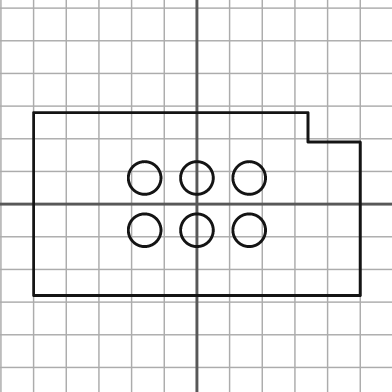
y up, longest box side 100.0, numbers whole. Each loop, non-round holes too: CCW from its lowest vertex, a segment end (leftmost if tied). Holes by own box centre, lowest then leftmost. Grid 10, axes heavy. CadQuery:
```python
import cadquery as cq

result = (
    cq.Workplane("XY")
    .moveTo(-50.0, -28.0)
    .lineTo(50.0, -28.0)
    .lineTo(50.0, 19.0)
    .lineTo(34.0, 19.0)
    .lineTo(34.0, 28.0)
    .lineTo(-50.0, 28.0)
    .close()
    .moveTo(-16.0, -8.0)
    .circle(5.0)
    .moveTo(0.0, -8.0)
    .circle(5.0)
    .moveTo(16.0, -8.0)
    .circle(5.0)
    .moveTo(-16.0, 8.0)
    .circle(5.0)
    .moveTo(0.0, 8.0)
    .circle(5.0)
    .moveTo(16.0, 8.0)
    .circle(5.0)
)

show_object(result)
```